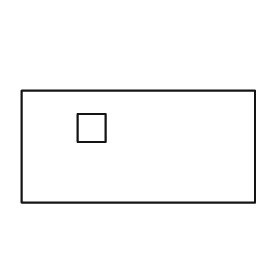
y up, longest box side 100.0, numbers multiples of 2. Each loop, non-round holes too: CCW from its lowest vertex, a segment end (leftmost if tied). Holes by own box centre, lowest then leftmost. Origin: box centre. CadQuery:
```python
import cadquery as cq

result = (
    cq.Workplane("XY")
    .moveTo(-50.0, -24.0)
    .lineTo(50.0, -24.0)
    .lineTo(50.0, 24.0)
    .lineTo(-50.0, 24.0)
    .close()
    .moveTo(-26.0, 2.0)
    .lineTo(-14.0, 2.0)
    .lineTo(-14.0, 14.0)
    .lineTo(-26.0, 14.0)
    .close()
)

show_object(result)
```